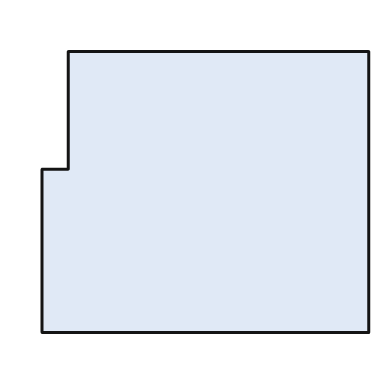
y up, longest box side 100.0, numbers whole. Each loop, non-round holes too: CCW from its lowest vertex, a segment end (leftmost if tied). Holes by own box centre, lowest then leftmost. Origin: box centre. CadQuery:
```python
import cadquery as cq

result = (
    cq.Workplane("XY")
    .moveTo(-50.0, -43.0)
    .lineTo(50.0, -43.0)
    .lineTo(50.0, 43.0)
    .lineTo(-42.0, 43.0)
    .lineTo(-42.0, 7.0)
    .lineTo(-50.0, 7.0)
    .close()
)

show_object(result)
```